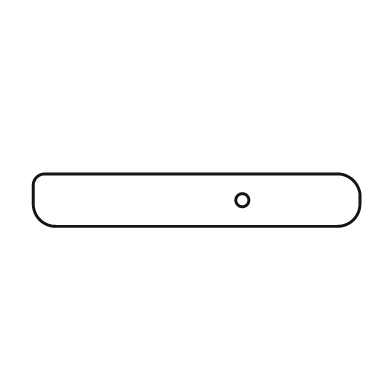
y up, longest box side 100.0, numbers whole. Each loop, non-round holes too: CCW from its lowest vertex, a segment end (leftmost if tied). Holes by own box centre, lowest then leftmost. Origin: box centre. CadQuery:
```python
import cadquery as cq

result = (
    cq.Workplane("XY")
    .moveTo(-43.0, -8.0)
    .lineTo(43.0, -8.0)
    .threePointArc((48.0, -6.0), (50.0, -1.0))
    .lineTo(50.0, 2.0)
    .threePointArc((48.0, 6.0), (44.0, 8.0))
    .lineTo(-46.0, 8.0)
    .threePointArc((-49.0, 7.0), (-50.0, 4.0))
    .lineTo(-50.0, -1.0)
    .threePointArc((-48.0, -6.0), (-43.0, -8.0))
    .close()
    .moveTo(14.0, 0.0)
    .circle(2.0)
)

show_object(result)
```